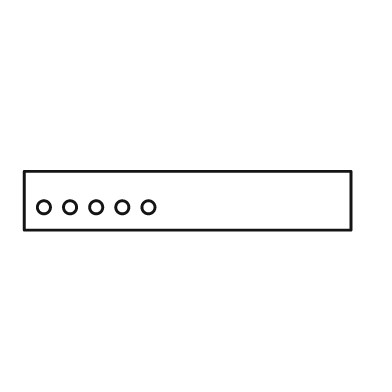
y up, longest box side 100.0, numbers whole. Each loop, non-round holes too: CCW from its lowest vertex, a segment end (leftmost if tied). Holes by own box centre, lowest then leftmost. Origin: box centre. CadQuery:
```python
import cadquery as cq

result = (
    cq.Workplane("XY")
    .moveTo(-50.0, -9.0)
    .lineTo(50.0, -9.0)
    .lineTo(50.0, 9.0)
    .lineTo(-50.0, 9.0)
    .close()
    .moveTo(-44.0, -2.0)
    .circle(2.0)
    .moveTo(-36.0, -2.0)
    .circle(2.0)
    .moveTo(-28.0, -2.0)
    .circle(2.0)
    .moveTo(-20.0, -2.0)
    .circle(2.0)
    .moveTo(-12.0, -2.0)
    .circle(2.0)
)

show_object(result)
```